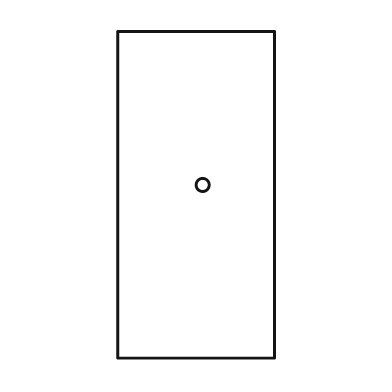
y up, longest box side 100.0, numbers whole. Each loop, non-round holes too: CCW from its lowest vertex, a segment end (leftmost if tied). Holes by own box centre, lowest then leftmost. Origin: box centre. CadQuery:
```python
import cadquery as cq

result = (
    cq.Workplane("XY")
    .moveTo(-24.0, -50.0)
    .lineTo(24.0, -50.0)
    .lineTo(24.0, 50.0)
    .lineTo(-24.0, 50.0)
    .close()
    .moveTo(2.0, 3.0)
    .circle(2.0)
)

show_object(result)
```